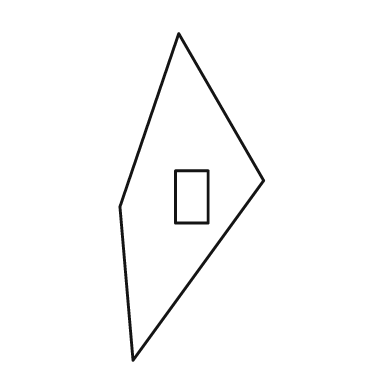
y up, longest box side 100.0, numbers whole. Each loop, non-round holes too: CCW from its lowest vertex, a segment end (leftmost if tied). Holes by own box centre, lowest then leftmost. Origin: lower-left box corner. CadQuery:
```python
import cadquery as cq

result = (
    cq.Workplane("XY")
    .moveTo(4.0, 0.0)
    .lineTo(44.0, 55.0)
    .lineTo(18.0, 100.0)
    .lineTo(0.0, 47.0)
    .close()
    .moveTo(17.0, 42.0)
    .lineTo(27.0, 42.0)
    .lineTo(27.0, 58.0)
    .lineTo(17.0, 58.0)
    .close()
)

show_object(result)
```